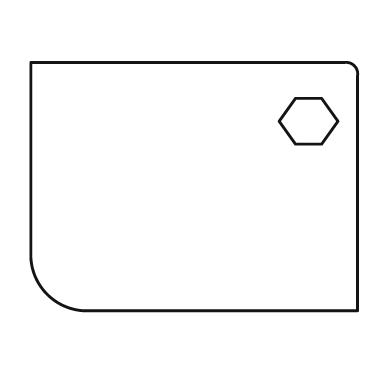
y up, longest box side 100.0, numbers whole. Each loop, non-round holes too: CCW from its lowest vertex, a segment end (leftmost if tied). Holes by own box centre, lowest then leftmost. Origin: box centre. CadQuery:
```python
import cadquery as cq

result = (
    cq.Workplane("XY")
    .moveTo(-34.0, -38.0)
    .lineTo(50.0, -38.0)
    .lineTo(50.0, 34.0)
    .threePointArc((49.0, 37.0), (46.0, 38.0))
    .lineTo(-50.0, 38.0)
    .lineTo(-50.0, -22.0)
    .threePointArc((-45.0, -33.0), (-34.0, -38.0))
    .close()
    .moveTo(31.0, 13.0)
    .lineTo(39.0, 13.0)
    .lineTo(44.0, 20.0)
    .lineTo(39.0, 27.0)
    .lineTo(31.0, 27.0)
    .lineTo(26.0, 20.0)
    .close()
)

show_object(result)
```